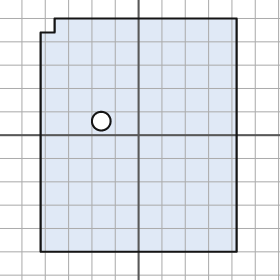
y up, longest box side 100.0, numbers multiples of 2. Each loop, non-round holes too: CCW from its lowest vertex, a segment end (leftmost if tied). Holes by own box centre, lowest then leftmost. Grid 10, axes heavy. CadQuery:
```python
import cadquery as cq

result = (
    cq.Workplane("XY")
    .moveTo(-42.0, -50.0)
    .lineTo(42.0, -50.0)
    .lineTo(42.0, 50.0)
    .lineTo(-36.0, 50.0)
    .lineTo(-36.0, 44.0)
    .lineTo(-42.0, 44.0)
    .close()
    .moveTo(-16.0, 6.0)
    .circle(4.0)
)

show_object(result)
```